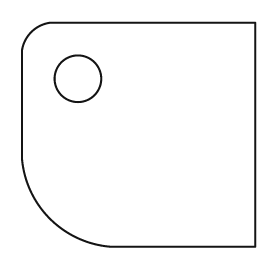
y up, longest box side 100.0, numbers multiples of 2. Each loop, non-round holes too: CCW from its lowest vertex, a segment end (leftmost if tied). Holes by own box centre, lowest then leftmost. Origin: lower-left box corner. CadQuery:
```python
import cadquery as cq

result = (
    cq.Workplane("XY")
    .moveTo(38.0, 0.0)
    .lineTo(100.0, 0.0)
    .lineTo(100.0, 96.0)
    .lineTo(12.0, 96.0)
    .threePointArc((4.0, 92.0), (0.0, 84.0))
    .lineTo(0.0, 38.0)
    .threePointArc((12.0, 12.0), (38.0, 0.0))
    .close()
    .moveTo(24.0, 72.0)
    .circle(10.0)
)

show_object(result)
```